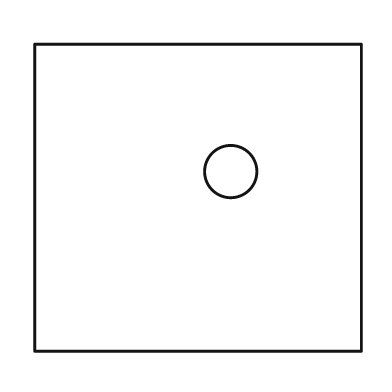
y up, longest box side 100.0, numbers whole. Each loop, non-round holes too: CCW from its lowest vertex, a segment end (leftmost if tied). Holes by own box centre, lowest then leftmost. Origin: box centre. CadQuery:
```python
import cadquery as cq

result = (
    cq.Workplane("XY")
    .moveTo(-50.0, -47.0)
    .lineTo(50.0, -47.0)
    .lineTo(50.0, 47.0)
    .lineTo(-50.0, 47.0)
    .close()
    .moveTo(10.0, 8.0)
    .circle(8.0)
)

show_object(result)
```